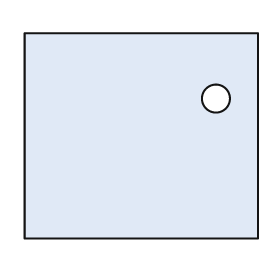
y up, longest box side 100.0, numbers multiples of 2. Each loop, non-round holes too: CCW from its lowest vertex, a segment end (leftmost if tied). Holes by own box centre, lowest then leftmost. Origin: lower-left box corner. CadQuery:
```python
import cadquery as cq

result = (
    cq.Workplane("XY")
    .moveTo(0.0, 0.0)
    .lineTo(100.0, 0.0)
    .lineTo(100.0, 88.0)
    .lineTo(0.0, 88.0)
    .close()
    .moveTo(82.0, 60.0)
    .circle(6.0)
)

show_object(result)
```